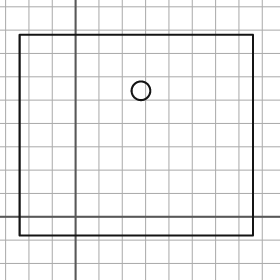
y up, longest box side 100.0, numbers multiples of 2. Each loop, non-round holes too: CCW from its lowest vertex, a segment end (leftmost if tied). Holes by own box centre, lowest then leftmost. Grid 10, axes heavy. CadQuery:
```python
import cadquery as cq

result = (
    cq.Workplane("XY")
    .moveTo(-24.0, -8.0)
    .lineTo(76.0, -8.0)
    .lineTo(76.0, 78.0)
    .lineTo(-24.0, 78.0)
    .close()
    .moveTo(28.0, 54.0)
    .circle(4.0)
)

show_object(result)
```